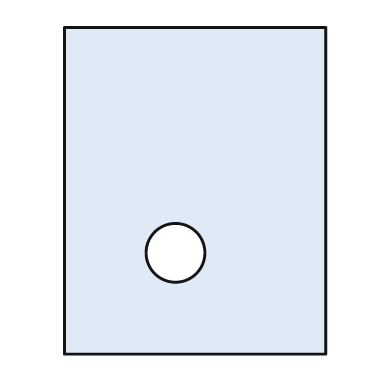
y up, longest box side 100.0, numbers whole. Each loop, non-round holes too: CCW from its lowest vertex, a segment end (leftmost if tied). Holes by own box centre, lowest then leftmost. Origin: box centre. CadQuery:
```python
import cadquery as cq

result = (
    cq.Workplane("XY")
    .moveTo(-40.0, -50.0)
    .lineTo(40.0, -50.0)
    .lineTo(40.0, 50.0)
    .lineTo(-40.0, 50.0)
    .close()
    .moveTo(-6.0, -19.0)
    .circle(9.0)
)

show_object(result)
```